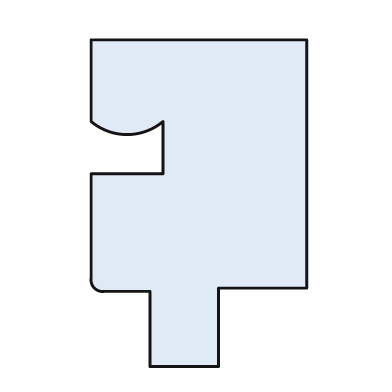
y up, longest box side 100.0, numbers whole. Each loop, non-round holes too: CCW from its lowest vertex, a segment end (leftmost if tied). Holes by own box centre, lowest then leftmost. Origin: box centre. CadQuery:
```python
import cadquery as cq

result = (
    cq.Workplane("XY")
    .moveTo(-15.0, -50.0)
    .lineTo(6.0, -50.0)
    .lineTo(6.0, -26.0)
    .lineTo(33.0, -26.0)
    .lineTo(33.0, 50.0)
    .lineTo(-33.0, 50.0)
    .lineTo(-33.0, 25.0)
    .threePointArc((-22.0, 21.0), (-11.0, 25.0))
    .lineTo(-11.0, 9.0)
    .lineTo(-33.0, 9.0)
    .lineTo(-33.0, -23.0)
    .threePointArc((-32.0, -26.0), (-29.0, -27.0))
    .lineTo(-15.0, -27.0)
    .close()
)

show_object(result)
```